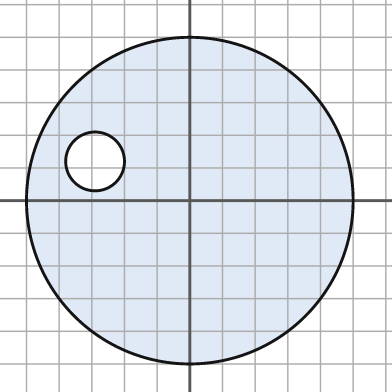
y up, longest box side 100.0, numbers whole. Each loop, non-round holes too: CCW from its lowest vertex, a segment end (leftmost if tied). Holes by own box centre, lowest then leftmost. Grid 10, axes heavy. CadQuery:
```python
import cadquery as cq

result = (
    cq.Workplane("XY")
    .moveTo(0.0, 0.0)
    .circle(50.0)
    .moveTo(-29.0, 12.0)
    .circle(9.0)
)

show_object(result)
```